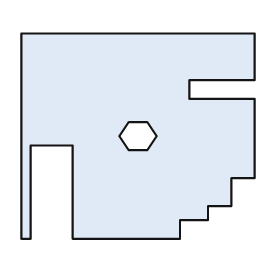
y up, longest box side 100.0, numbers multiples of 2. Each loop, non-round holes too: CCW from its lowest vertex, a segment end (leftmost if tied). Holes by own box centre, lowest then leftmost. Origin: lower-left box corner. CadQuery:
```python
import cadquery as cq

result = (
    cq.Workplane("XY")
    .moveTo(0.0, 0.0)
    .lineTo(4.0, 0.0)
    .lineTo(4.0, 40.0)
    .lineTo(22.0, 40.0)
    .lineTo(22.0, 0.0)
    .lineTo(68.0, 0.0)
    .lineTo(68.0, 8.0)
    .lineTo(80.0, 8.0)
    .lineTo(80.0, 14.0)
    .lineTo(90.0, 14.0)
    .lineTo(90.0, 26.0)
    .lineTo(100.0, 26.0)
    .lineTo(100.0, 60.0)
    .lineTo(72.0, 60.0)
    .lineTo(72.0, 68.0)
    .lineTo(100.0, 68.0)
    .lineTo(100.0, 88.0)
    .lineTo(0.0, 88.0)
    .close()
    .moveTo(46.0, 38.0)
    .lineTo(54.0, 38.0)
    .lineTo(58.0, 44.0)
    .lineTo(54.0, 50.0)
    .lineTo(46.0, 50.0)
    .lineTo(42.0, 44.0)
    .close()
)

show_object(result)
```